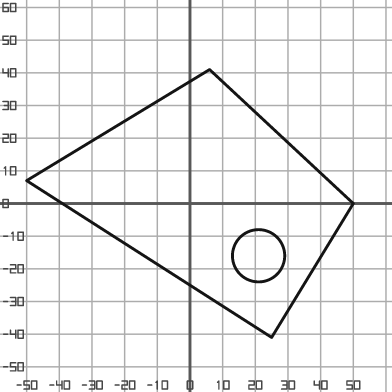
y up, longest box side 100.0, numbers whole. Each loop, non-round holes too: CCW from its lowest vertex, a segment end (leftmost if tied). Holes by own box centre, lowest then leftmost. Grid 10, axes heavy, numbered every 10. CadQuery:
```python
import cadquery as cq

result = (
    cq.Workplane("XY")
    .moveTo(25.0, -41.0)
    .lineTo(50.0, 0.0)
    .lineTo(6.0, 41.0)
    .lineTo(-50.0, 7.0)
    .close()
    .moveTo(21.0, -16.0)
    .circle(8.0)
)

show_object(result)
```